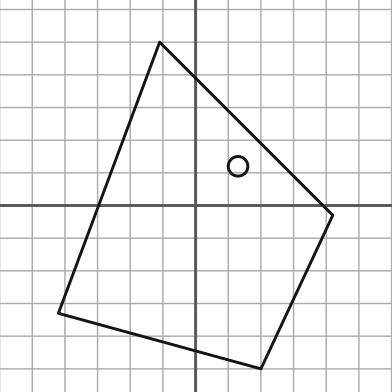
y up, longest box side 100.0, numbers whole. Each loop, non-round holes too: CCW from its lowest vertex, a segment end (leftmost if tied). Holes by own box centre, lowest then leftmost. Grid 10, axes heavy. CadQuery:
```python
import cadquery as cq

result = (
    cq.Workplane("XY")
    .moveTo(20.0, -50.0)
    .lineTo(42.0, -3.0)
    .lineTo(-11.0, 50.0)
    .lineTo(-42.0, -33.0)
    .close()
    .moveTo(13.0, 12.0)
    .circle(3.0)
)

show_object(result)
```